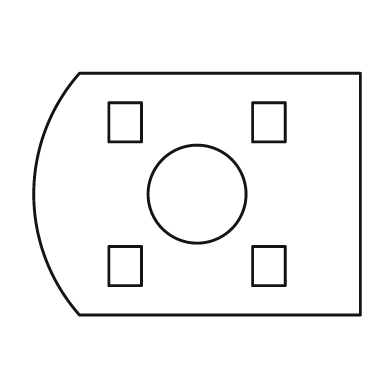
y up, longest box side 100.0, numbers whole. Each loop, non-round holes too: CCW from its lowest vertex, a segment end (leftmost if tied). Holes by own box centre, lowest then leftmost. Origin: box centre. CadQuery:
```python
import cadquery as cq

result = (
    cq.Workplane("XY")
    .moveTo(-36.0, -37.0)
    .lineTo(50.0, -37.0)
    .lineTo(50.0, 37.0)
    .lineTo(-36.0, 37.0)
    .threePointArc((-50.0, 0.0), (-36.0, -37.0))
    .close()
    .moveTo(-27.0, -28.0)
    .lineTo(-17.0, -28.0)
    .lineTo(-17.0, -16.0)
    .lineTo(-27.0, -16.0)
    .close()
    .moveTo(17.0, -28.0)
    .lineTo(27.0, -28.0)
    .lineTo(27.0, -16.0)
    .lineTo(17.0, -16.0)
    .close()
    .moveTo(0.0, 0.0)
    .circle(15.0)
    .moveTo(-27.0, 16.0)
    .lineTo(-17.0, 16.0)
    .lineTo(-17.0, 28.0)
    .lineTo(-27.0, 28.0)
    .close()
    .moveTo(17.0, 16.0)
    .lineTo(27.0, 16.0)
    .lineTo(27.0, 28.0)
    .lineTo(17.0, 28.0)
    .close()
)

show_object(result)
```